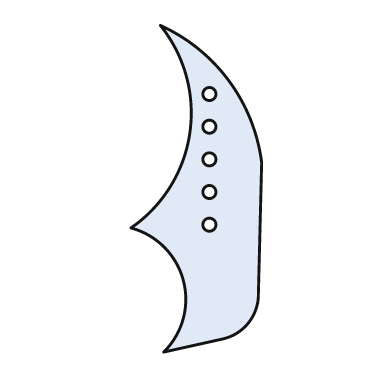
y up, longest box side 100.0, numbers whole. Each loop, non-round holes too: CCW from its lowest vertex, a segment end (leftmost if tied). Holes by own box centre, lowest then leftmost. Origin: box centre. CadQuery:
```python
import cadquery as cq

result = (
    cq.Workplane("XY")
    .moveTo(-10.0, -50.0)
    .lineTo(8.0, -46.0)
    .threePointArc((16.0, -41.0), (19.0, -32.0))
    .lineTo(20.0, 8.0)
    .threePointArc((10.0, 33.0), (-11.0, 50.0))
    .threePointArc((-2.0, 17.0), (-20.0, -12.0))
    .threePointArc((-4.0, -28.0), (-10.0, -50.0))
    .close()
    .moveTo(4.0, -11.0)
    .circle(2.0)
    .moveTo(4.0, -1.0)
    .circle(2.0)
    .moveTo(4.0, 9.0)
    .circle(2.0)
    .moveTo(4.0, 19.0)
    .circle(2.0)
    .moveTo(4.0, 29.0)
    .circle(2.0)
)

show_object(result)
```